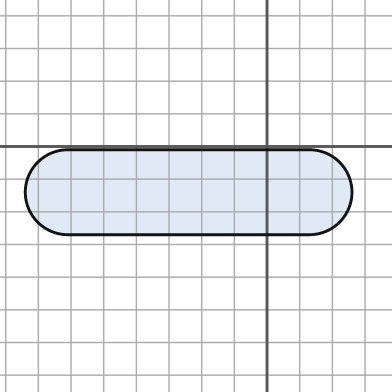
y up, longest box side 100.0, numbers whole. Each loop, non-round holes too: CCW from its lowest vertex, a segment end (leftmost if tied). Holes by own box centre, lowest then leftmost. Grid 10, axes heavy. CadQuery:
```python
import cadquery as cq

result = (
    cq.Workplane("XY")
    .moveTo(-61.0, -27.0)
    .lineTo(13.0, -27.0)
    .threePointArc((26.0, -14.0), (13.0, -1.0))
    .lineTo(-61.0, -1.0)
    .threePointArc((-74.0, -14.0), (-61.0, -27.0))
    .close()
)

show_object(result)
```